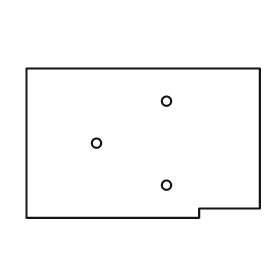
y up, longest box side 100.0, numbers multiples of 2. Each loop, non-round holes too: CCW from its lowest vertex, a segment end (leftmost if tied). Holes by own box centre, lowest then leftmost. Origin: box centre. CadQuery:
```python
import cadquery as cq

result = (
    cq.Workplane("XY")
    .moveTo(-50.0, -32.0)
    .lineTo(24.0, -32.0)
    .lineTo(24.0, -28.0)
    .lineTo(50.0, -28.0)
    .lineTo(50.0, 32.0)
    .lineTo(-50.0, 32.0)
    .close()
    .moveTo(10.0, -18.0)
    .circle(2.0)
    .moveTo(-20.0, 0.0)
    .circle(2.0)
    .moveTo(10.0, 18.0)
    .circle(2.0)
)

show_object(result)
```